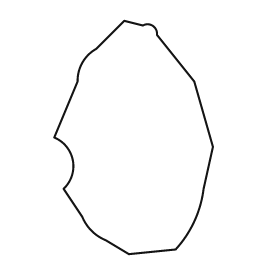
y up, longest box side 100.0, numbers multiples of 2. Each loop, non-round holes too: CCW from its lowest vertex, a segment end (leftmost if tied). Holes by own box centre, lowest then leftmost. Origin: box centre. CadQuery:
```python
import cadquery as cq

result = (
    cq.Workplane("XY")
    .moveTo(-2.0, -50.0)
    .lineTo(18.0, -48.0)
    .threePointArc((26.0, -36.0), (30.0, -22.0))
    .lineTo(34.0, -4.0)
    .lineTo(26.0, 24.0)
    .lineTo(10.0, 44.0)
    .threePointArc((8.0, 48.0), (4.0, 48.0))
    .lineTo(-4.0, 50.0)
    .lineTo(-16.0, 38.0)
    .threePointArc((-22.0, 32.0), (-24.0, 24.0))
    .lineTo(-34.0, 0.0)
    .threePointArc((-26.0, -10.0), (-30.0, -22.0))
    .lineTo(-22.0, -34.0)
    .threePointArc((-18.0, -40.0), (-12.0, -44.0))
    .close()
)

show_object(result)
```